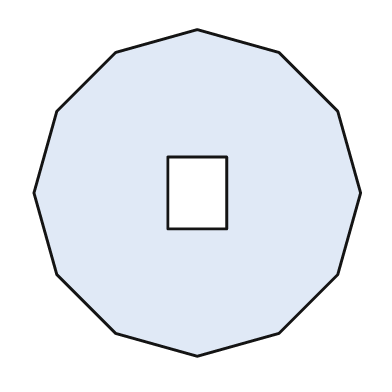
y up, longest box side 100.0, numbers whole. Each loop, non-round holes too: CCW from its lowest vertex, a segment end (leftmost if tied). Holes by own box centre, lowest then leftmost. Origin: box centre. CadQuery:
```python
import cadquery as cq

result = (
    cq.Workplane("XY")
    .moveTo(0.0, -50.0)
    .lineTo(25.0, -43.0)
    .lineTo(43.0, -25.0)
    .lineTo(50.0, 0.0)
    .lineTo(43.0, 25.0)
    .lineTo(25.0, 43.0)
    .lineTo(0.0, 50.0)
    .lineTo(-25.0, 43.0)
    .lineTo(-43.0, 25.0)
    .lineTo(-50.0, 0.0)
    .lineTo(-43.0, -25.0)
    .lineTo(-25.0, -43.0)
    .close()
    .moveTo(-9.0, -11.0)
    .lineTo(9.0, -11.0)
    .lineTo(9.0, 11.0)
    .lineTo(-9.0, 11.0)
    .close()
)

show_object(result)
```